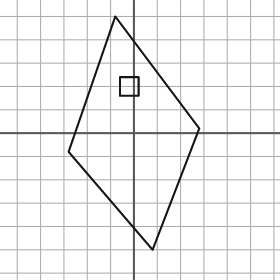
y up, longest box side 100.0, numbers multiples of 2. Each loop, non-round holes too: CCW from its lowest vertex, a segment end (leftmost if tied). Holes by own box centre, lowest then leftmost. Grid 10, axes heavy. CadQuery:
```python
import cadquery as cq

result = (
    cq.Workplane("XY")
    .moveTo(8.0, -50.0)
    .lineTo(28.0, 2.0)
    .lineTo(-8.0, 50.0)
    .lineTo(-28.0, -8.0)
    .close()
    .moveTo(-6.0, 16.0)
    .lineTo(2.0, 16.0)
    .lineTo(2.0, 24.0)
    .lineTo(-6.0, 24.0)
    .close()
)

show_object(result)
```